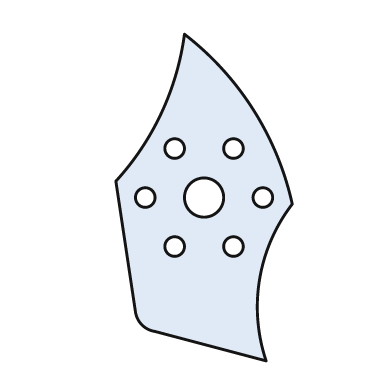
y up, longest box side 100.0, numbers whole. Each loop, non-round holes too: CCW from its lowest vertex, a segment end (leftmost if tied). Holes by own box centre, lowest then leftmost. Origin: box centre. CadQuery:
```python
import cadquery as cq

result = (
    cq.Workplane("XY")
    .moveTo(19.0, -50.0)
    .threePointArc((17.0, -25.0), (27.0, -2.0))
    .threePointArc((15.0, 27.0), (-6.0, 50.0))
    .threePointArc((-13.0, 26.0), (-27.0, 5.0))
    .lineTo(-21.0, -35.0)
    .threePointArc((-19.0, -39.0), (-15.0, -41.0))
    .close()
    .moveTo(-9.0, -15.0)
    .circle(3.0)
    .moveTo(9.0, -15.0)
    .circle(3.0)
    .moveTo(-18.0, 0.0)
    .circle(3.0)
    .moveTo(0.0, 0.0)
    .circle(6.0)
    .moveTo(18.0, 0.0)
    .circle(3.0)
    .moveTo(-9.0, 15.0)
    .circle(3.0)
    .moveTo(9.0, 15.0)
    .circle(3.0)
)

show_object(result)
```